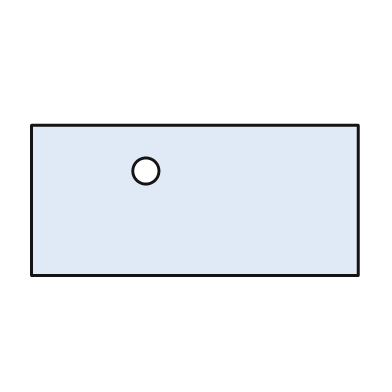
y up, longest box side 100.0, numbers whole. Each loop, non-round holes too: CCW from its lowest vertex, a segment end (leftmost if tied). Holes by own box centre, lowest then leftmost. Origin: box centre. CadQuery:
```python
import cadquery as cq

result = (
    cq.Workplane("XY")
    .moveTo(-50.0, -23.0)
    .lineTo(50.0, -23.0)
    .lineTo(50.0, 23.0)
    .lineTo(-50.0, 23.0)
    .close()
    .moveTo(-15.0, 9.0)
    .circle(4.0)
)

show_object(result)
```